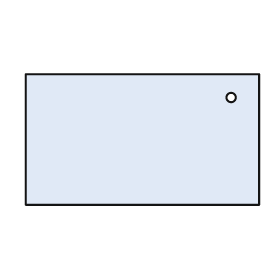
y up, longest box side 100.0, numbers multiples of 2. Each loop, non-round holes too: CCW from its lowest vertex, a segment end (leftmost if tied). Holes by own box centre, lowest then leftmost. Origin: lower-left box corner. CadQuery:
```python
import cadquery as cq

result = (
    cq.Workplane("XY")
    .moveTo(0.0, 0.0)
    .lineTo(100.0, 0.0)
    .lineTo(100.0, 56.0)
    .lineTo(0.0, 56.0)
    .close()
    .moveTo(88.0, 46.0)
    .circle(2.0)
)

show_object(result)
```